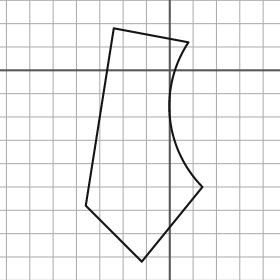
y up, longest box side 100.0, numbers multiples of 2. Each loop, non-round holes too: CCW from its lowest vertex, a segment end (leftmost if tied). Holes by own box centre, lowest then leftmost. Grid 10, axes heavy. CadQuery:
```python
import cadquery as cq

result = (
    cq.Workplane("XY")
    .moveTo(-12.0, -82.0)
    .lineTo(14.0, -50.0)
    .threePointArc((0.0, -20.0), (8.0, 12.0))
    .lineTo(-24.0, 18.0)
    .lineTo(-36.0, -58.0)
    .close()
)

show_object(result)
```